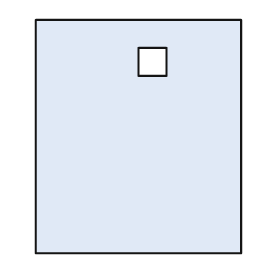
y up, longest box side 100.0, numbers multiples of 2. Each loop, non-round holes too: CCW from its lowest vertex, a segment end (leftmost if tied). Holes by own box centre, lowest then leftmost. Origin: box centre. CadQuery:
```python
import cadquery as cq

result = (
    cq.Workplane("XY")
    .moveTo(-44.0, -50.0)
    .lineTo(44.0, -50.0)
    .lineTo(44.0, 50.0)
    .lineTo(-44.0, 50.0)
    .close()
    .moveTo(0.0, 26.0)
    .lineTo(12.0, 26.0)
    .lineTo(12.0, 38.0)
    .lineTo(0.0, 38.0)
    .close()
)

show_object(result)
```